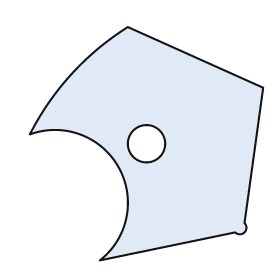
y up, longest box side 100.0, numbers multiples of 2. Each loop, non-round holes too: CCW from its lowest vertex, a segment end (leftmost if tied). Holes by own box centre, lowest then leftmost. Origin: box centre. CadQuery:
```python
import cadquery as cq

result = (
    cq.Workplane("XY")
    .moveTo(-20.0, -50.0)
    .lineTo(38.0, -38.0)
    .threePointArc((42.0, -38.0), (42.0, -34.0))
    .lineTo(50.0, 24.0)
    .lineTo(-8.0, 50.0)
    .threePointArc((-32.0, 30.0), (-50.0, 4.0))
    .threePointArc((-12.0, -10.0), (-20.0, -50.0))
    .close()
    .moveTo(0.0, 0.0)
    .circle(8.0)
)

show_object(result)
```